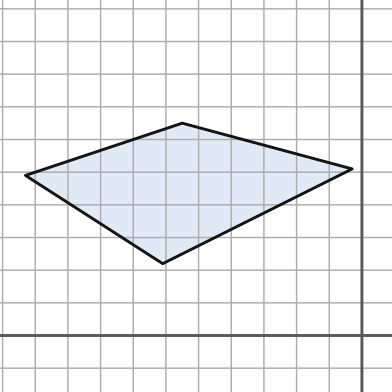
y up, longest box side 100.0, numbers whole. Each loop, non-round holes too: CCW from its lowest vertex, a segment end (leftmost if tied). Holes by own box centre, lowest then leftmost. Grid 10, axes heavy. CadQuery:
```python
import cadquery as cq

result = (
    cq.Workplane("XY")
    .moveTo(-61.0, 22.0)
    .lineTo(-3.0, 51.0)
    .lineTo(-55.0, 65.0)
    .lineTo(-103.0, 49.0)
    .close()
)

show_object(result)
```